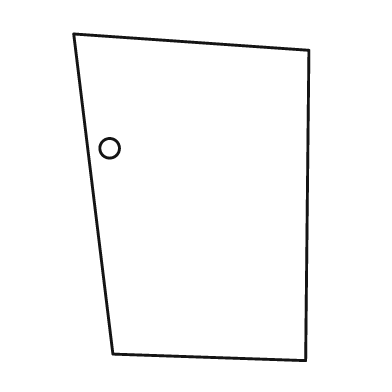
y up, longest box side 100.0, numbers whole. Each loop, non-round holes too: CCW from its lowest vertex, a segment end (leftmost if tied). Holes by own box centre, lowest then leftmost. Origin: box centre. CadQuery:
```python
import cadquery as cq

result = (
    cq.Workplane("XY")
    .moveTo(35.0, -50.0)
    .lineTo(36.0, 45.0)
    .lineTo(-36.0, 50.0)
    .lineTo(-24.0, -48.0)
    .close()
    .moveTo(-25.0, 15.0)
    .circle(3.0)
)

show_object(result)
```